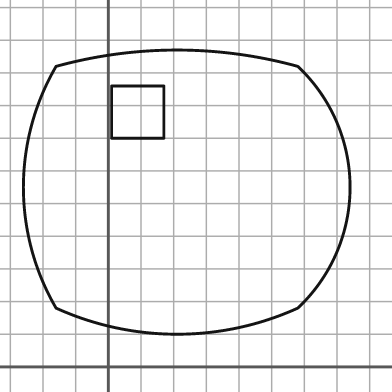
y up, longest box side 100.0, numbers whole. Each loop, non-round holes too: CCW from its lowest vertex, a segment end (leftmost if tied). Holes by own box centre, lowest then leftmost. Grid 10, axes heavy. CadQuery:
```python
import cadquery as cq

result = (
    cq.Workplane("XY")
    .moveTo(-16.0, 18.0)
    .threePointArc((21.0, 10.0), (58.0, 18.0))
    .threePointArc((74.0, 55.0), (58.0, 92.0))
    .threePointArc((21.0, 97.0), (-16.0, 92.0))
    .threePointArc((-26.0, 55.0), (-16.0, 18.0))
    .close()
    .moveTo(1.0, 70.0)
    .lineTo(17.0, 70.0)
    .lineTo(17.0, 86.0)
    .lineTo(1.0, 86.0)
    .close()
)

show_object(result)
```